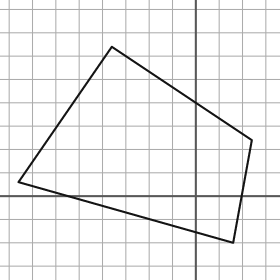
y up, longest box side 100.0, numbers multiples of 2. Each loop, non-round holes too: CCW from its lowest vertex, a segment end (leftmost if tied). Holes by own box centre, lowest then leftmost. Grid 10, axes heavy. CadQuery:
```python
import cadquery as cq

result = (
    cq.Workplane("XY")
    .moveTo(16.0, -20.0)
    .lineTo(24.0, 24.0)
    .lineTo(-36.0, 64.0)
    .lineTo(-76.0, 6.0)
    .close()
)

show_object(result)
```